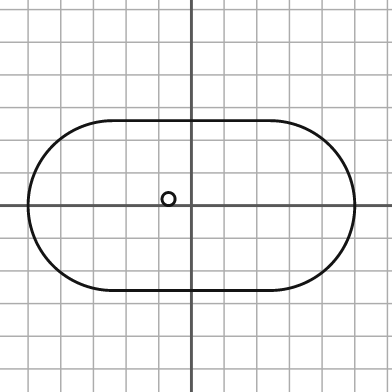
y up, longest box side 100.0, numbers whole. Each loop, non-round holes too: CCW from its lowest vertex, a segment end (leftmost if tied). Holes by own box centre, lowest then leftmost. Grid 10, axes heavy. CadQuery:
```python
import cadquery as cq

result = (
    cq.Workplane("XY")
    .moveTo(-24.0, -26.0)
    .lineTo(24.0, -26.0)
    .threePointArc((50.0, 0.0), (24.0, 26.0))
    .lineTo(-24.0, 26.0)
    .threePointArc((-50.0, 0.0), (-24.0, -26.0))
    .close()
    .moveTo(-7.0, 2.0)
    .circle(2.0)
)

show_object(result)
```